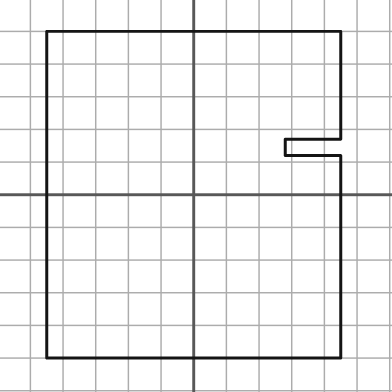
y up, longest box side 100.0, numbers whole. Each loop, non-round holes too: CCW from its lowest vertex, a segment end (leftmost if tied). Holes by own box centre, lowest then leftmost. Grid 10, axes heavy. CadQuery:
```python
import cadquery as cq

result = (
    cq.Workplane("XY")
    .moveTo(-45.0, -50.0)
    .lineTo(45.0, -50.0)
    .lineTo(45.0, 12.0)
    .lineTo(28.0, 12.0)
    .lineTo(28.0, 17.0)
    .lineTo(45.0, 17.0)
    .lineTo(45.0, 50.0)
    .lineTo(-45.0, 50.0)
    .close()
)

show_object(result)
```